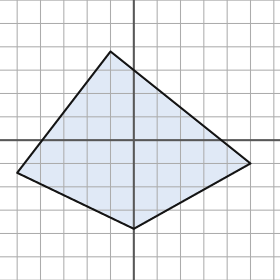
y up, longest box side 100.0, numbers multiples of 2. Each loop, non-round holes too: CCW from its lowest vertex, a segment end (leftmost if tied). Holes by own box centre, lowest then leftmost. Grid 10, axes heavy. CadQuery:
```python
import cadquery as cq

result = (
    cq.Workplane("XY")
    .moveTo(0.0, -38.0)
    .lineTo(50.0, -10.0)
    .lineTo(-10.0, 38.0)
    .lineTo(-50.0, -14.0)
    .close()
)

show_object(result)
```